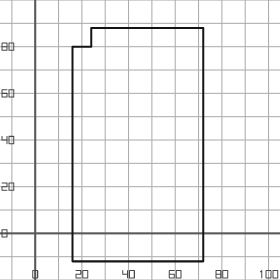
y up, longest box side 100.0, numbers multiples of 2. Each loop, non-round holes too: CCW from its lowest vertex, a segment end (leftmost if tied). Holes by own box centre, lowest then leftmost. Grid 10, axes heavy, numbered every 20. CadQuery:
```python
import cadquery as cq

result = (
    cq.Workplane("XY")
    .moveTo(16.0, -12.0)
    .lineTo(72.0, -12.0)
    .lineTo(72.0, 88.0)
    .lineTo(24.0, 88.0)
    .lineTo(24.0, 80.0)
    .lineTo(16.0, 80.0)
    .close()
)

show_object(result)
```